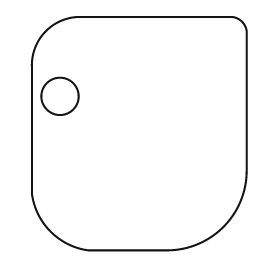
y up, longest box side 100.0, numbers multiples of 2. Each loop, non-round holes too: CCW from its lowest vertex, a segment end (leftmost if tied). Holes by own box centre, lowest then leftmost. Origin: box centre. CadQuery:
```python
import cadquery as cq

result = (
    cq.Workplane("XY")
    .moveTo(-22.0, -50.0)
    .lineTo(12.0, -50.0)
    .threePointArc((36.0, -40.0), (46.0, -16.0))
    .lineTo(46.0, 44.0)
    .threePointArc((44.0, 48.0), (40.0, 50.0))
    .lineTo(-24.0, 50.0)
    .threePointArc((-40.0, 44.0), (-46.0, 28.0))
    .lineTo(-46.0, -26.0)
    .threePointArc((-38.0, -42.0), (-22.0, -50.0))
    .close()
    .moveTo(-34.0, 16.0)
    .circle(8.0)
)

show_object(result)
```